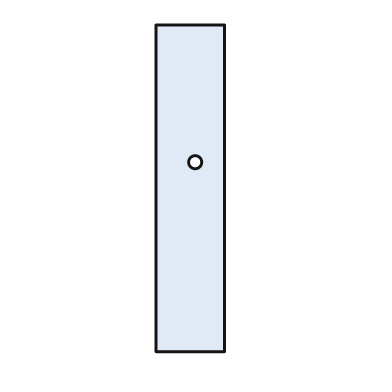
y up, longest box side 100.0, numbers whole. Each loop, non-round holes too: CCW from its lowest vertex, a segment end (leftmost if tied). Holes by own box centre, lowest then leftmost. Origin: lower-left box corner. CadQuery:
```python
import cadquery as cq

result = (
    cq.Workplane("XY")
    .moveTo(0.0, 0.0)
    .lineTo(21.0, 0.0)
    .lineTo(21.0, 100.0)
    .lineTo(0.0, 100.0)
    .close()
    .moveTo(12.0, 58.0)
    .circle(2.0)
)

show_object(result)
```